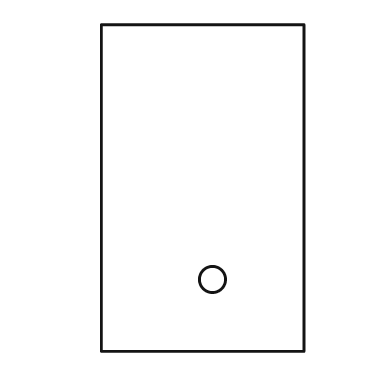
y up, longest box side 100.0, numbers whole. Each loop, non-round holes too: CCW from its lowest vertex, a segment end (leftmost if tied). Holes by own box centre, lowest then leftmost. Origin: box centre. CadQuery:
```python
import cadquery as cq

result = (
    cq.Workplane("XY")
    .moveTo(-31.0, -50.0)
    .lineTo(31.0, -50.0)
    .lineTo(31.0, 50.0)
    .lineTo(-31.0, 50.0)
    .close()
    .moveTo(3.0, -28.0)
    .circle(4.0)
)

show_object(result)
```